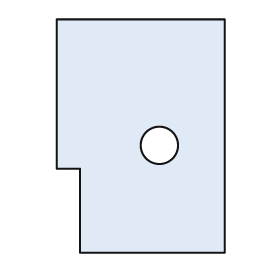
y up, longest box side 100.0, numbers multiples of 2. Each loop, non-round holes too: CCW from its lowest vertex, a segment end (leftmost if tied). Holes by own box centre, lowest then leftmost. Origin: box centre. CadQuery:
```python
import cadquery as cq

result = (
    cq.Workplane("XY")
    .moveTo(-26.0, -50.0)
    .lineTo(36.0, -50.0)
    .lineTo(36.0, 50.0)
    .lineTo(-36.0, 50.0)
    .lineTo(-36.0, -14.0)
    .lineTo(-26.0, -14.0)
    .close()
    .moveTo(8.0, -4.0)
    .circle(8.0)
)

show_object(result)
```